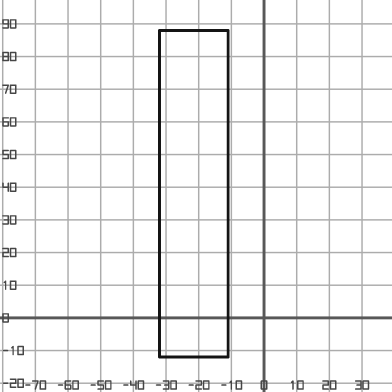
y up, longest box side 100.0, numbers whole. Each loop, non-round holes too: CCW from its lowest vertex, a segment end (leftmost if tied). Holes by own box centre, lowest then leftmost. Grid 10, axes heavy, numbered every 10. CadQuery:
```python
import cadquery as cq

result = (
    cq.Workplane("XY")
    .moveTo(-32.0, -12.0)
    .lineTo(-11.0, -12.0)
    .lineTo(-11.0, 88.0)
    .lineTo(-32.0, 88.0)
    .close()
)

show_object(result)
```